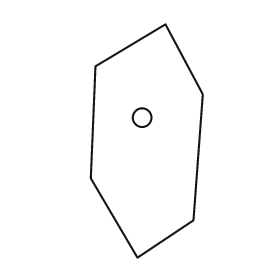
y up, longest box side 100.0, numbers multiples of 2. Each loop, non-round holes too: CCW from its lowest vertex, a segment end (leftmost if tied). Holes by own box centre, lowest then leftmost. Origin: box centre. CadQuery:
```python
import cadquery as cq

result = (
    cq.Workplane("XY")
    .moveTo(-4.0, -50.0)
    .lineTo(20.0, -34.0)
    .lineTo(24.0, 20.0)
    .lineTo(8.0, 50.0)
    .lineTo(-22.0, 32.0)
    .lineTo(-24.0, -16.0)
    .close()
    .moveTo(-2.0, 10.0)
    .circle(4.0)
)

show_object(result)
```